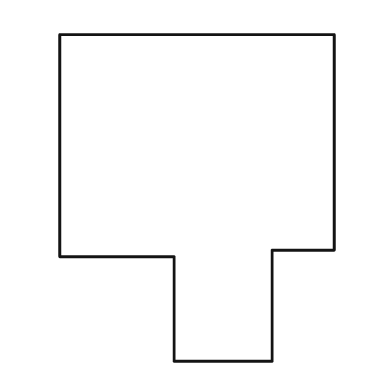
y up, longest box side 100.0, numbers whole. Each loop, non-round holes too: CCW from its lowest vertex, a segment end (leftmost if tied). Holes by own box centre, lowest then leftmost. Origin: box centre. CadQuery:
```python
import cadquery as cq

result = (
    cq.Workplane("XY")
    .moveTo(-7.0, -50.0)
    .lineTo(23.0, -50.0)
    .lineTo(23.0, -16.0)
    .lineTo(42.0, -16.0)
    .lineTo(42.0, 50.0)
    .lineTo(-42.0, 50.0)
    .lineTo(-42.0, -18.0)
    .lineTo(-7.0, -18.0)
    .close()
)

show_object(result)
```